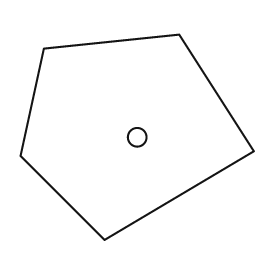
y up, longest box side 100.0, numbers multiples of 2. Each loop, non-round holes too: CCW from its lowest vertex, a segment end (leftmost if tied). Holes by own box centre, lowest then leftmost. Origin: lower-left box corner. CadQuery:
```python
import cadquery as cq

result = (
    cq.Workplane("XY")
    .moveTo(36.0, 0.0)
    .lineTo(100.0, 38.0)
    .lineTo(68.0, 88.0)
    .lineTo(10.0, 82.0)
    .lineTo(0.0, 36.0)
    .close()
    .moveTo(50.0, 44.0)
    .circle(4.0)
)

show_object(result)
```